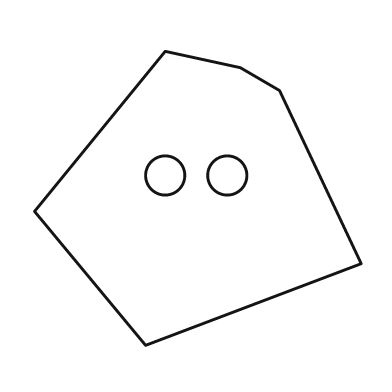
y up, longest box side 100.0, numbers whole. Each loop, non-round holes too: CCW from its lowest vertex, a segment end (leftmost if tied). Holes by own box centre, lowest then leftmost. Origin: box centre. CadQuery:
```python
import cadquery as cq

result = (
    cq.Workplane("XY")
    .moveTo(-16.0, -45.0)
    .lineTo(50.0, -20.0)
    .lineTo(25.0, 33.0)
    .lineTo(13.0, 40.0)
    .lineTo(-10.0, 45.0)
    .lineTo(-50.0, -4.0)
    .close()
    .moveTo(-10.0, 7.0)
    .circle(6.0)
    .moveTo(9.0, 7.0)
    .circle(6.0)
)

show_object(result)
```